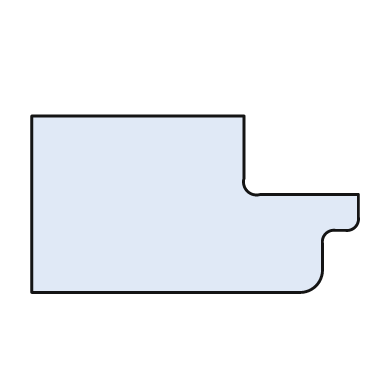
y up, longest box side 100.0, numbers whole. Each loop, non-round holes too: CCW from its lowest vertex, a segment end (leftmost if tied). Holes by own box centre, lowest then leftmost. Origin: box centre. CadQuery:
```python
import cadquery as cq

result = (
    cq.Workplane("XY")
    .moveTo(-50.0, -27.0)
    .lineTo(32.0, -27.0)
    .threePointArc((37.0, -25.0), (39.0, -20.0))
    .lineTo(39.0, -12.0)
    .threePointArc((40.0, -9.0), (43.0, -8.0))
    .lineTo(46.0, -8.0)
    .threePointArc((49.0, -7.0), (50.0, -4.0))
    .lineTo(50.0, 3.0)
    .lineTo(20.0, 3.0)
    .threePointArc((16.0, 4.0), (15.0, 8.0))
    .lineTo(15.0, 27.0)
    .lineTo(-50.0, 27.0)
    .close()
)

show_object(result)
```